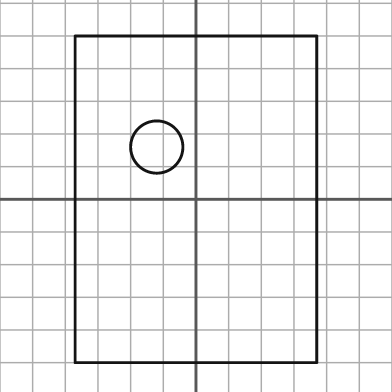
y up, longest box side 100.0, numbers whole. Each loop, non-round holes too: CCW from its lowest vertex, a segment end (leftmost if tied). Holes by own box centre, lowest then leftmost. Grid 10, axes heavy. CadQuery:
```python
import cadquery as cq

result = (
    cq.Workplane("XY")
    .moveTo(-37.0, -50.0)
    .lineTo(37.0, -50.0)
    .lineTo(37.0, 50.0)
    .lineTo(-37.0, 50.0)
    .close()
    .moveTo(-12.0, 16.0)
    .circle(8.0)
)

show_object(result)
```